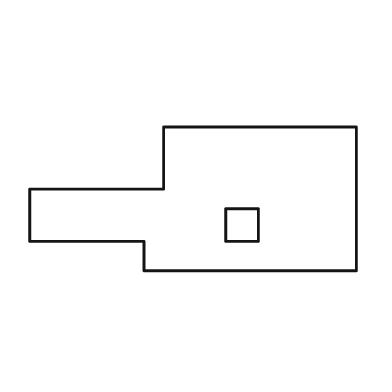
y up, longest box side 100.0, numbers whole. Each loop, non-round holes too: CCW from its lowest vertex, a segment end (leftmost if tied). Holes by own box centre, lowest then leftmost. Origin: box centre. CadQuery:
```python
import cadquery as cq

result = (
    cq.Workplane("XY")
    .moveTo(-15.0, -22.0)
    .lineTo(50.0, -22.0)
    .lineTo(50.0, 22.0)
    .lineTo(-9.0, 22.0)
    .lineTo(-9.0, 3.0)
    .lineTo(-50.0, 3.0)
    .lineTo(-50.0, -13.0)
    .lineTo(-15.0, -13.0)
    .close()
    .moveTo(10.0, -13.0)
    .lineTo(20.0, -13.0)
    .lineTo(20.0, -3.0)
    .lineTo(10.0, -3.0)
    .close()
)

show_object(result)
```